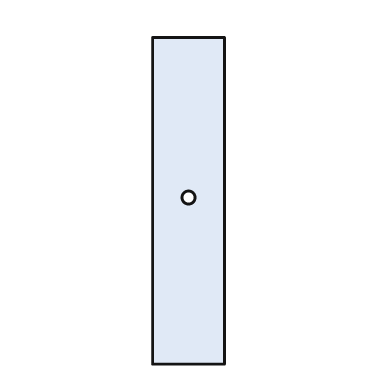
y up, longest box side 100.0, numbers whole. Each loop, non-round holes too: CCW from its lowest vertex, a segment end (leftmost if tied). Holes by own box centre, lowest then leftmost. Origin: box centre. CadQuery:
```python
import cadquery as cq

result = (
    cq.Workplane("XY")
    .moveTo(-11.0, -50.0)
    .lineTo(11.0, -50.0)
    .lineTo(11.0, 50.0)
    .lineTo(-11.0, 50.0)
    .close()
    .moveTo(0.0, 1.0)
    .circle(2.0)
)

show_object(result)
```